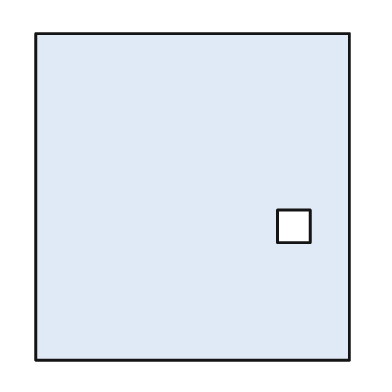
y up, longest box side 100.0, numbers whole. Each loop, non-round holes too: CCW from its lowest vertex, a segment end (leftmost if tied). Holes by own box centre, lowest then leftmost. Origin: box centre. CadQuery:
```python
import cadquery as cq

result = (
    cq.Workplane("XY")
    .moveTo(-48.0, -50.0)
    .lineTo(48.0, -50.0)
    .lineTo(48.0, 50.0)
    .lineTo(-48.0, 50.0)
    .close()
    .moveTo(26.0, -14.0)
    .lineTo(36.0, -14.0)
    .lineTo(36.0, -4.0)
    .lineTo(26.0, -4.0)
    .close()
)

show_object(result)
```